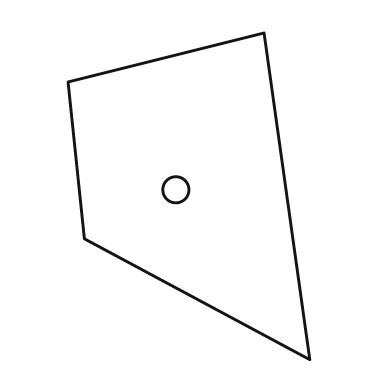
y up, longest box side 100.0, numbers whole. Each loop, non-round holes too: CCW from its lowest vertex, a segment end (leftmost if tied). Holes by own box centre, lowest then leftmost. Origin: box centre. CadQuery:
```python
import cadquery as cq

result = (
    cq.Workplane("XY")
    .moveTo(37.0, -50.0)
    .lineTo(23.0, 50.0)
    .lineTo(-37.0, 35.0)
    .lineTo(-32.0, -13.0)
    .close()
    .moveTo(-4.0, 2.0)
    .circle(4.0)
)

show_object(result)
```